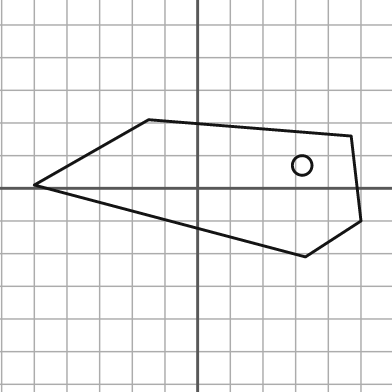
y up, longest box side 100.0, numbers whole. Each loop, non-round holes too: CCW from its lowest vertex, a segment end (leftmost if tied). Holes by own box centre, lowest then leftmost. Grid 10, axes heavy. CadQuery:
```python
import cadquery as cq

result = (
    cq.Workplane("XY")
    .moveTo(33.0, -21.0)
    .lineTo(50.0, -10.0)
    .lineTo(47.0, 16.0)
    .lineTo(-15.0, 21.0)
    .lineTo(-50.0, 1.0)
    .close()
    .moveTo(32.0, 7.0)
    .circle(3.0)
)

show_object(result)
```